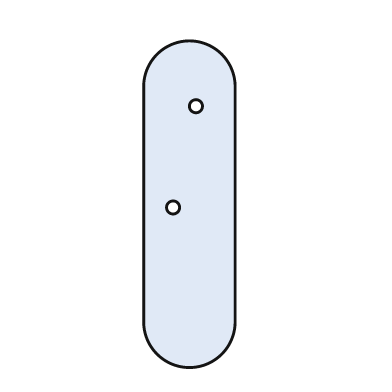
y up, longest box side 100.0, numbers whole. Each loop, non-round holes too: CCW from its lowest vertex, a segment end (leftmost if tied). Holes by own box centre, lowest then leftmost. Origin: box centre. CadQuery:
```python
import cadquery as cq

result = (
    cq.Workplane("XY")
    .moveTo(-14.0, -36.0)
    .threePointArc((0.0, -50.0), (14.0, -36.0))
    .lineTo(14.0, 36.0)
    .threePointArc((0.0, 50.0), (-14.0, 36.0))
    .close()
    .moveTo(-5.0, -1.0)
    .circle(2.0)
    .moveTo(2.0, 30.0)
    .circle(2.0)
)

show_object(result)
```